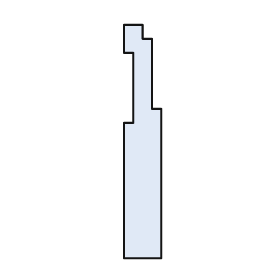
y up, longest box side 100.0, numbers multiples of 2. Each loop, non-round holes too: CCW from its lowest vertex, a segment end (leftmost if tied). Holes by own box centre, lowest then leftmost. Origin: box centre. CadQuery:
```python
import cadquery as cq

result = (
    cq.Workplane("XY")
    .moveTo(-8.0, -50.0)
    .lineTo(8.0, -50.0)
    .lineTo(8.0, 14.0)
    .lineTo(4.0, 14.0)
    .lineTo(4.0, 44.0)
    .lineTo(0.0, 44.0)
    .lineTo(0.0, 50.0)
    .lineTo(-8.0, 50.0)
    .lineTo(-8.0, 38.0)
    .lineTo(-4.0, 38.0)
    .lineTo(-4.0, 8.0)
    .lineTo(-8.0, 8.0)
    .close()
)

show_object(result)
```